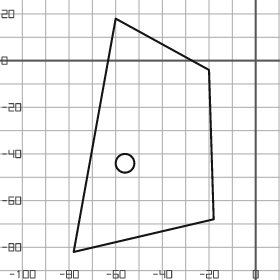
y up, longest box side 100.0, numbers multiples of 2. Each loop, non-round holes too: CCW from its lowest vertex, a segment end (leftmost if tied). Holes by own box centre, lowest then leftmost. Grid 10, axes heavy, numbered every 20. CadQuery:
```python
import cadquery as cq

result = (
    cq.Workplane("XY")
    .moveTo(-78.0, -82.0)
    .lineTo(-18.0, -68.0)
    .lineTo(-20.0, -4.0)
    .lineTo(-60.0, 18.0)
    .close()
    .moveTo(-56.0, -44.0)
    .circle(4.0)
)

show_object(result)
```